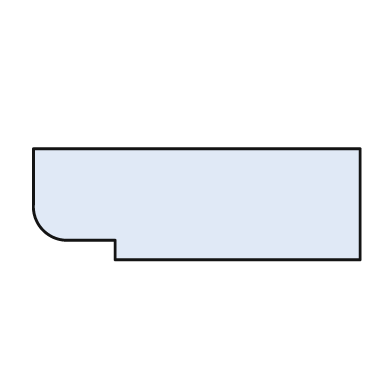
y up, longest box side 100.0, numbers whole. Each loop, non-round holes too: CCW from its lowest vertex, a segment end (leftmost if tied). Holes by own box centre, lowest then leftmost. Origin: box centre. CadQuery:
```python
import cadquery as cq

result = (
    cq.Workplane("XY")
    .moveTo(-25.0, -17.0)
    .lineTo(50.0, -17.0)
    .lineTo(50.0, 17.0)
    .lineTo(-50.0, 17.0)
    .lineTo(-50.0, 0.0)
    .threePointArc((-47.0, -8.0), (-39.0, -11.0))
    .lineTo(-25.0, -11.0)
    .close()
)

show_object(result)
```